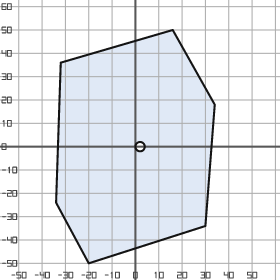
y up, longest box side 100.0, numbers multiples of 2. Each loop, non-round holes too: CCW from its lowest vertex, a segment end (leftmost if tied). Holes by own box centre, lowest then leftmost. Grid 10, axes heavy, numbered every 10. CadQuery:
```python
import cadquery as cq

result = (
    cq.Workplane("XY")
    .moveTo(-20.0, -50.0)
    .lineTo(30.0, -34.0)
    .lineTo(34.0, 18.0)
    .lineTo(16.0, 50.0)
    .lineTo(-32.0, 36.0)
    .lineTo(-34.0, -24.0)
    .close()
    .moveTo(2.0, 0.0)
    .circle(2.0)
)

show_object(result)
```